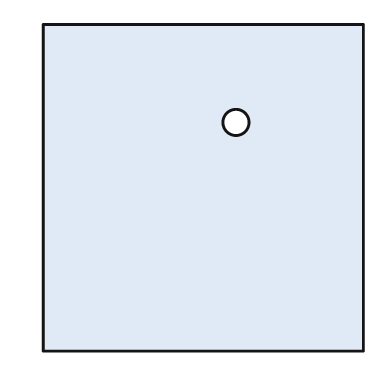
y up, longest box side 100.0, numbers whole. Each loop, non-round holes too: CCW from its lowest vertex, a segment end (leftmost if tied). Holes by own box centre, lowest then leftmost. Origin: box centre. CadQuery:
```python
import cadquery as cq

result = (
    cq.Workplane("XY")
    .moveTo(-49.0, -50.0)
    .lineTo(49.0, -50.0)
    .lineTo(49.0, 50.0)
    .lineTo(-49.0, 50.0)
    .close()
    .moveTo(10.0, 20.0)
    .circle(4.0)
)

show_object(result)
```